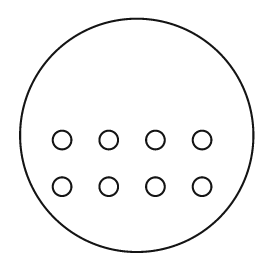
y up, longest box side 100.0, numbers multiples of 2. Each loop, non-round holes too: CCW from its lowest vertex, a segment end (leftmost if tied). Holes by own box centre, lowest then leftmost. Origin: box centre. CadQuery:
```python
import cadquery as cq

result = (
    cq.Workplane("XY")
    .moveTo(0.0, 0.0)
    .circle(50.0)
    .moveTo(-32.0, -22.0)
    .circle(4.0)
    .moveTo(-12.0, -22.0)
    .circle(4.0)
    .moveTo(8.0, -22.0)
    .circle(4.0)
    .moveTo(28.0, -22.0)
    .circle(4.0)
    .moveTo(-32.0, -2.0)
    .circle(4.0)
    .moveTo(-12.0, -2.0)
    .circle(4.0)
    .moveTo(8.0, -2.0)
    .circle(4.0)
    .moveTo(28.0, -2.0)
    .circle(4.0)
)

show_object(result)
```